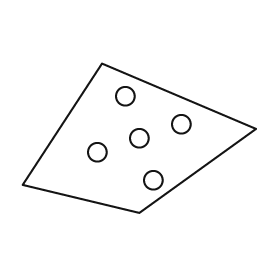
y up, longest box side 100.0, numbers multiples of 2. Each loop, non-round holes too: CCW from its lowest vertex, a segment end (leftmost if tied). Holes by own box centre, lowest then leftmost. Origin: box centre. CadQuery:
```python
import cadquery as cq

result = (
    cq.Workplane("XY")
    .moveTo(0.0, -32.0)
    .lineTo(50.0, 4.0)
    .lineTo(-16.0, 32.0)
    .lineTo(-50.0, -20.0)
    .close()
    .moveTo(6.0, -18.0)
    .circle(4.0)
    .moveTo(-18.0, -6.0)
    .circle(4.0)
    .moveTo(0.0, 0.0)
    .circle(4.0)
    .moveTo(18.0, 6.0)
    .circle(4.0)
    .moveTo(-6.0, 18.0)
    .circle(4.0)
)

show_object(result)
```